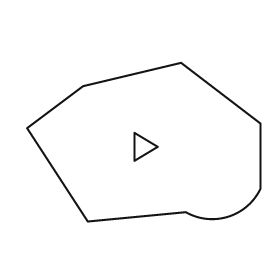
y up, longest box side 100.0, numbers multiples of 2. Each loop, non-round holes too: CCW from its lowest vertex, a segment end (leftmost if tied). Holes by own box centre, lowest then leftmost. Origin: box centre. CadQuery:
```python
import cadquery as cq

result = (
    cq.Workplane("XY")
    .moveTo(-24.0, -34.0)
    .lineTo(18.0, -30.0)
    .threePointArc((36.0, -32.0), (50.0, -20.0))
    .lineTo(50.0, 8.0)
    .lineTo(16.0, 34.0)
    .lineTo(-26.0, 24.0)
    .lineTo(-50.0, 6.0)
    .close()
    .moveTo(-4.0, -8.0)
    .lineTo(6.0, -2.0)
    .lineTo(-4.0, 4.0)
    .close()
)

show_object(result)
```